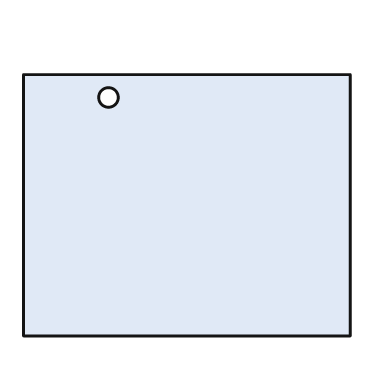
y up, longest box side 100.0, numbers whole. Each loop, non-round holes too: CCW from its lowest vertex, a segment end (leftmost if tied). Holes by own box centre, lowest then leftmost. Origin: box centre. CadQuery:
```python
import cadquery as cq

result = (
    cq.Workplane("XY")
    .moveTo(-50.0, -40.0)
    .lineTo(50.0, -40.0)
    .lineTo(50.0, 40.0)
    .lineTo(-50.0, 40.0)
    .close()
    .moveTo(-24.0, 33.0)
    .circle(3.0)
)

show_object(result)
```